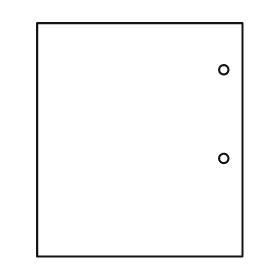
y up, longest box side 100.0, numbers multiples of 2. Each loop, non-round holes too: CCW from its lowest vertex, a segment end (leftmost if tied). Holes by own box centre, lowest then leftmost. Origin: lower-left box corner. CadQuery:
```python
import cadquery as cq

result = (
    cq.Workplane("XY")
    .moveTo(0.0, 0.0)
    .lineTo(88.0, 0.0)
    .lineTo(88.0, 100.0)
    .lineTo(0.0, 100.0)
    .close()
    .moveTo(80.0, 42.0)
    .circle(2.0)
    .moveTo(80.0, 80.0)
    .circle(2.0)
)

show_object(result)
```